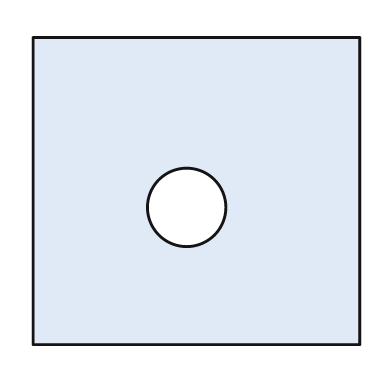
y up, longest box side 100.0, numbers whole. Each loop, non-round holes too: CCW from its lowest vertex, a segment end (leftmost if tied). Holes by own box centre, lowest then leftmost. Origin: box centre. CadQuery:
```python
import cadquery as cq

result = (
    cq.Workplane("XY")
    .moveTo(-50.0, -47.0)
    .lineTo(50.0, -47.0)
    .lineTo(50.0, 47.0)
    .lineTo(-50.0, 47.0)
    .close()
    .moveTo(-3.0, -5.0)
    .circle(12.0)
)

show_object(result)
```